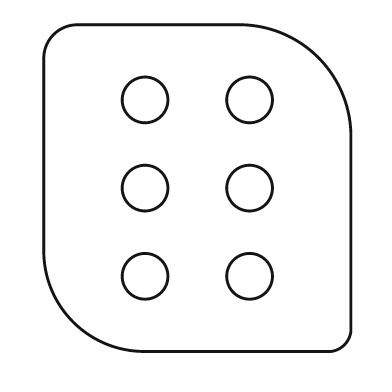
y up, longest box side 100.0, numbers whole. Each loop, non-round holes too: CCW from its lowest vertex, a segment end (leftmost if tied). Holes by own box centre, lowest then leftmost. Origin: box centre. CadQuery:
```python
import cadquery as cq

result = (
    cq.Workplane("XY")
    .moveTo(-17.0, -50.0)
    .lineTo(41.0, -50.0)
    .threePointArc((45.0, -48.0), (47.0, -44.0))
    .lineTo(47.0, 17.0)
    .threePointArc((37.0, 40.0), (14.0, 50.0))
    .lineTo(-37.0, 50.0)
    .threePointArc((-44.0, 47.0), (-47.0, 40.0))
    .lineTo(-47.0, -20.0)
    .threePointArc((-38.0, -41.0), (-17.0, -50.0))
    .close()
    .moveTo(-16.0, -27.0)
    .circle(7.0)
    .moveTo(16.0, -27.0)
    .circle(7.0)
    .moveTo(-16.0, 0.0)
    .circle(7.0)
    .moveTo(16.0, 0.0)
    .circle(7.0)
    .moveTo(-16.0, 27.0)
    .circle(7.0)
    .moveTo(16.0, 27.0)
    .circle(7.0)
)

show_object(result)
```